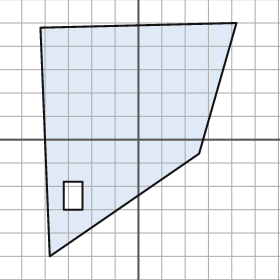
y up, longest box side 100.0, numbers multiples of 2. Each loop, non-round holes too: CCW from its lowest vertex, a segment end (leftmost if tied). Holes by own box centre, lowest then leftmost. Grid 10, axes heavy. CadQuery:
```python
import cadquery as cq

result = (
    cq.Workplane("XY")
    .moveTo(-38.0, -50.0)
    .lineTo(26.0, -6.0)
    .lineTo(42.0, 50.0)
    .lineTo(-42.0, 48.0)
    .close()
    .moveTo(-32.0, -30.0)
    .lineTo(-24.0, -30.0)
    .lineTo(-24.0, -18.0)
    .lineTo(-32.0, -18.0)
    .close()
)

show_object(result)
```